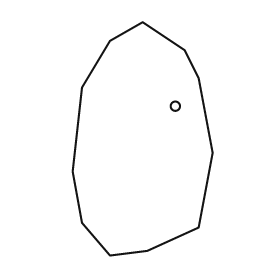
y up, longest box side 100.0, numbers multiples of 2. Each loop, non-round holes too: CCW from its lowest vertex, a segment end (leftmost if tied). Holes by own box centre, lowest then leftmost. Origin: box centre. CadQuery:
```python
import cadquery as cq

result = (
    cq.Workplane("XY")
    .moveTo(-14.0, -50.0)
    .lineTo(2.0, -48.0)
    .lineTo(24.0, -38.0)
    .lineTo(30.0, -6.0)
    .lineTo(24.0, 26.0)
    .lineTo(18.0, 38.0)
    .lineTo(0.0, 50.0)
    .lineTo(-14.0, 42.0)
    .lineTo(-26.0, 22.0)
    .lineTo(-30.0, -14.0)
    .lineTo(-26.0, -36.0)
    .close()
    .moveTo(14.0, 14.0)
    .circle(2.0)
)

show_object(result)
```